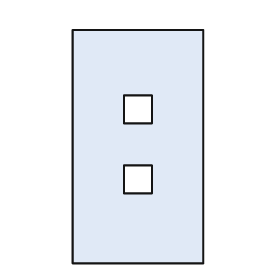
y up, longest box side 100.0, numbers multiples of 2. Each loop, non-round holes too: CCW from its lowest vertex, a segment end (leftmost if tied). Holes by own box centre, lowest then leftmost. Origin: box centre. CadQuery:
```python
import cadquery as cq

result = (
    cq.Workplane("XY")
    .moveTo(-28.0, -50.0)
    .lineTo(28.0, -50.0)
    .lineTo(28.0, 50.0)
    .lineTo(-28.0, 50.0)
    .close()
    .moveTo(-6.0, -20.0)
    .lineTo(6.0, -20.0)
    .lineTo(6.0, -8.0)
    .lineTo(-6.0, -8.0)
    .close()
    .moveTo(-6.0, 10.0)
    .lineTo(6.0, 10.0)
    .lineTo(6.0, 22.0)
    .lineTo(-6.0, 22.0)
    .close()
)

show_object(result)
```